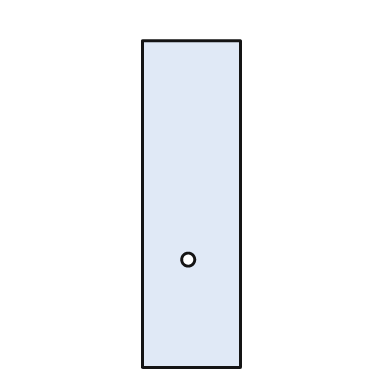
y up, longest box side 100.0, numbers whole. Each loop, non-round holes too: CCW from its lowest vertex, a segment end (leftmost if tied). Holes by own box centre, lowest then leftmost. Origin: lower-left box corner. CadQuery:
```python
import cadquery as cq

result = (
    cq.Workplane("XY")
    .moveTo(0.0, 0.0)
    .lineTo(30.0, 0.0)
    .lineTo(30.0, 100.0)
    .lineTo(0.0, 100.0)
    .close()
    .moveTo(14.0, 33.0)
    .circle(2.0)
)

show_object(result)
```